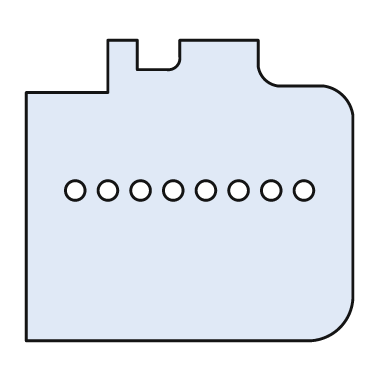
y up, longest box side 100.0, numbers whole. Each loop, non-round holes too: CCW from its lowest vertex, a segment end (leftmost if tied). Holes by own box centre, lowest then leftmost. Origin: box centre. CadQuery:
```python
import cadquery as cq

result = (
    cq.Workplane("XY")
    .moveTo(-50.0, -46.0)
    .lineTo(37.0, -46.0)
    .threePointArc((46.0, -42.0), (50.0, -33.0))
    .lineTo(50.0, 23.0)
    .threePointArc((47.0, 29.0), (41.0, 32.0))
    .lineTo(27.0, 32.0)
    .threePointArc((23.0, 34.0), (21.0, 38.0))
    .lineTo(21.0, 46.0)
    .lineTo(-3.0, 46.0)
    .lineTo(-3.0, 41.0)
    .threePointArc((-4.0, 38.0), (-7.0, 37.0))
    .lineTo(-16.0, 37.0)
    .lineTo(-16.0, 46.0)
    .lineTo(-25.0, 46.0)
    .lineTo(-25.0, 30.0)
    .lineTo(-50.0, 30.0)
    .close()
    .moveTo(-35.0, 0.0)
    .circle(3.0)
    .moveTo(-25.0, 0.0)
    .circle(3.0)
    .moveTo(-15.0, 0.0)
    .circle(3.0)
    .moveTo(-5.0, 0.0)
    .circle(3.0)
    .moveTo(5.0, 0.0)
    .circle(3.0)
    .moveTo(15.0, 0.0)
    .circle(3.0)
    .moveTo(25.0, 0.0)
    .circle(3.0)
    .moveTo(35.0, 0.0)
    .circle(3.0)
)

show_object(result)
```